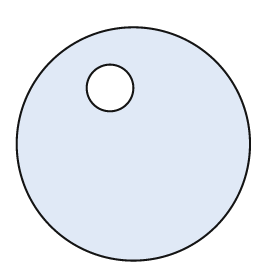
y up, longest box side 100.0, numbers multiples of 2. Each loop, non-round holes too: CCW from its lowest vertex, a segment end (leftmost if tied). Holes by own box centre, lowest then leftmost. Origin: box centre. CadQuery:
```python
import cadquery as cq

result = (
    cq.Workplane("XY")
    .moveTo(0.0, 0.0)
    .circle(50.0)
    .moveTo(-10.0, 24.0)
    .circle(10.0)
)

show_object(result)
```